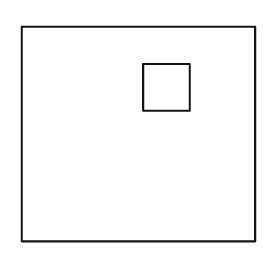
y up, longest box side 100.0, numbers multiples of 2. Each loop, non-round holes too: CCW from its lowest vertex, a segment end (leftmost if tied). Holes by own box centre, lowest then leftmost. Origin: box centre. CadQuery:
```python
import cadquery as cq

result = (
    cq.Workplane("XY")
    .moveTo(-50.0, -46.0)
    .lineTo(50.0, -46.0)
    .lineTo(50.0, 46.0)
    .lineTo(-50.0, 46.0)
    .close()
    .moveTo(2.0, 10.0)
    .lineTo(22.0, 10.0)
    .lineTo(22.0, 30.0)
    .lineTo(2.0, 30.0)
    .close()
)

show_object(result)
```